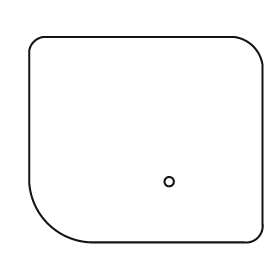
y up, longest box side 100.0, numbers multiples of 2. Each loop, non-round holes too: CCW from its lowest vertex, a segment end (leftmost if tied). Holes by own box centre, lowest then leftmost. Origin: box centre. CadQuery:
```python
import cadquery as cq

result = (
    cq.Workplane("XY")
    .moveTo(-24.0, -44.0)
    .lineTo(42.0, -44.0)
    .threePointArc((48.0, -42.0), (50.0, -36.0))
    .lineTo(50.0, 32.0)
    .threePointArc((46.0, 40.0), (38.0, 44.0))
    .lineTo(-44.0, 44.0)
    .threePointArc((-48.0, 42.0), (-50.0, 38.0))
    .lineTo(-50.0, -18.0)
    .threePointArc((-42.0, -36.0), (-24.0, -44.0))
    .close()
    .moveTo(10.0, -18.0)
    .circle(2.0)
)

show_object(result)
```